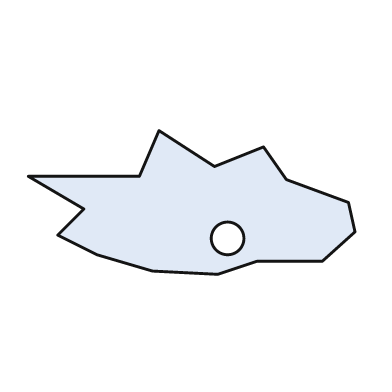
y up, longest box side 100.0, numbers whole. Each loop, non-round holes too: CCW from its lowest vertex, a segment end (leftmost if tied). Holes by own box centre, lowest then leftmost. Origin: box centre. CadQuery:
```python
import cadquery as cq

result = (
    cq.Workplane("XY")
    .moveTo(8.0, -22.0)
    .lineTo(20.0, -18.0)
    .lineTo(40.0, -18.0)
    .lineTo(50.0, -9.0)
    .lineTo(48.0, 0.0)
    .lineTo(29.0, 7.0)
    .lineTo(22.0, 17.0)
    .lineTo(7.0, 11.0)
    .lineTo(-10.0, 22.0)
    .lineTo(-16.0, 8.0)
    .lineTo(-50.0, 8.0)
    .lineTo(-33.0, -2.0)
    .lineTo(-41.0, -10.0)
    .lineTo(-29.0, -16.0)
    .lineTo(-12.0, -21.0)
    .close()
    .moveTo(11.0, -11.0)
    .circle(5.0)
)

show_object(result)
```